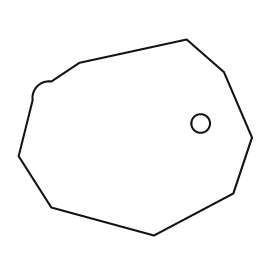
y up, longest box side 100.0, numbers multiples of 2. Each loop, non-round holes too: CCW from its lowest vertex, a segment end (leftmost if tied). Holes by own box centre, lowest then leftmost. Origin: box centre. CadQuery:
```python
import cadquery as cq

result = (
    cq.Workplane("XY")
    .moveTo(8.0, -42.0)
    .lineTo(42.0, -24.0)
    .lineTo(50.0, 0.0)
    .lineTo(38.0, 28.0)
    .lineTo(22.0, 42.0)
    .lineTo(-24.0, 32.0)
    .lineTo(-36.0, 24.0)
    .threePointArc((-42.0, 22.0), (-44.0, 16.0))
    .lineTo(-50.0, -8.0)
    .lineTo(-36.0, -30.0)
    .close()
    .moveTo(28.0, 6.0)
    .circle(4.0)
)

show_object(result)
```